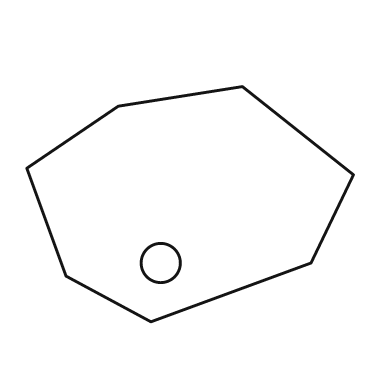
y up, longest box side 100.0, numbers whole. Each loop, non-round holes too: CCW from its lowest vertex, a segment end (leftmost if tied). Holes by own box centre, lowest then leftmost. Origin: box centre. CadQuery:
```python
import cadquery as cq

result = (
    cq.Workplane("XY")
    .moveTo(-12.0, -36.0)
    .lineTo(37.0, -18.0)
    .lineTo(50.0, 9.0)
    .lineTo(16.0, 36.0)
    .lineTo(-22.0, 30.0)
    .lineTo(-50.0, 11.0)
    .lineTo(-38.0, -22.0)
    .close()
    .moveTo(-9.0, -18.0)
    .circle(6.0)
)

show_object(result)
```